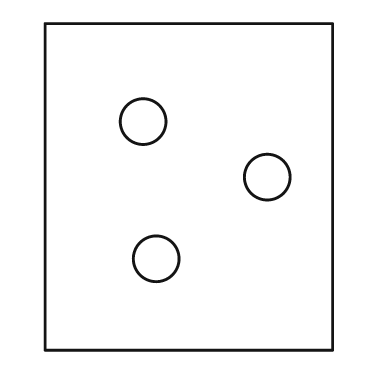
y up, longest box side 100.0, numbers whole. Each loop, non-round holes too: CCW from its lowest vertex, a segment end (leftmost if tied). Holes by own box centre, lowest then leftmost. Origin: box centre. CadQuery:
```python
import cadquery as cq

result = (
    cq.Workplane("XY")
    .moveTo(-44.0, -50.0)
    .lineTo(44.0, -50.0)
    .lineTo(44.0, 50.0)
    .lineTo(-44.0, 50.0)
    .close()
    .moveTo(-10.0, -22.0)
    .circle(7.0)
    .moveTo(24.0, 3.0)
    .circle(7.0)
    .moveTo(-14.0, 20.0)
    .circle(7.0)
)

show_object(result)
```